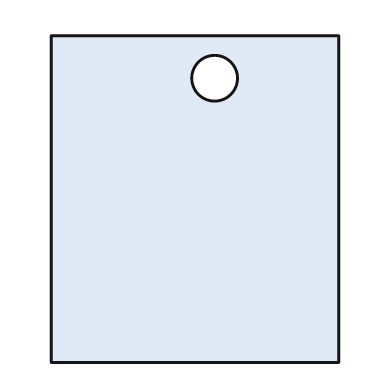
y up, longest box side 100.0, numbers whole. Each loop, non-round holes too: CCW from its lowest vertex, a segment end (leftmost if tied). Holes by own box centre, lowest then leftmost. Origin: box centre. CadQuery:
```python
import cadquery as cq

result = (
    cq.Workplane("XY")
    .moveTo(-44.0, -50.0)
    .lineTo(44.0, -50.0)
    .lineTo(44.0, 50.0)
    .lineTo(-44.0, 50.0)
    .close()
    .moveTo(6.0, 37.0)
    .circle(7.0)
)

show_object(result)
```